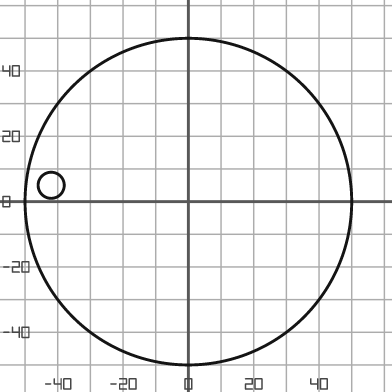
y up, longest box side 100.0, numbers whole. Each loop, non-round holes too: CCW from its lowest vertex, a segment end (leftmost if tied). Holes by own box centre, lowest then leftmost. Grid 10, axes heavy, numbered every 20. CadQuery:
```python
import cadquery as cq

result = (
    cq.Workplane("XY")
    .moveTo(0.0, 0.0)
    .circle(50.0)
    .moveTo(-42.0, 5.0)
    .circle(4.0)
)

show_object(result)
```